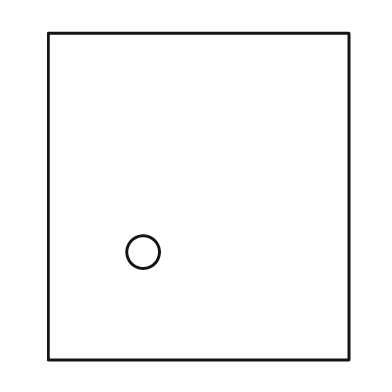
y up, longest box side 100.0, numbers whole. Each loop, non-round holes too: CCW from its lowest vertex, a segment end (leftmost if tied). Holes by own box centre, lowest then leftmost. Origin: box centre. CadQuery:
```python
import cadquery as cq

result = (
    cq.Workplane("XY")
    .moveTo(-46.0, -50.0)
    .lineTo(46.0, -50.0)
    .lineTo(46.0, 50.0)
    .lineTo(-46.0, 50.0)
    .close()
    .moveTo(-17.0, -17.0)
    .circle(5.0)
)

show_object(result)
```